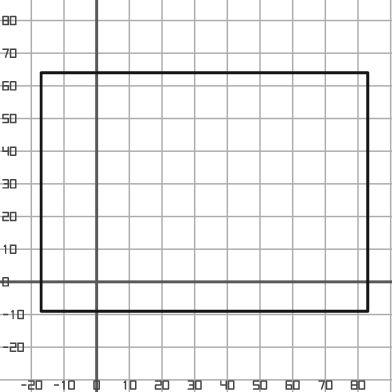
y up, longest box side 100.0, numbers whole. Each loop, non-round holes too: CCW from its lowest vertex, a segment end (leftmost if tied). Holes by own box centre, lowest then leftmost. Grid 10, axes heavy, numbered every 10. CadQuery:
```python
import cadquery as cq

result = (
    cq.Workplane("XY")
    .moveTo(-17.0, -9.0)
    .lineTo(83.0, -9.0)
    .lineTo(83.0, 64.0)
    .lineTo(-17.0, 64.0)
    .close()
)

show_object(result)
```